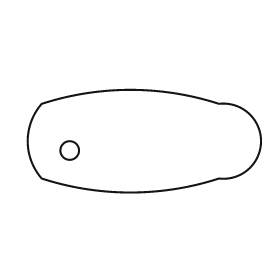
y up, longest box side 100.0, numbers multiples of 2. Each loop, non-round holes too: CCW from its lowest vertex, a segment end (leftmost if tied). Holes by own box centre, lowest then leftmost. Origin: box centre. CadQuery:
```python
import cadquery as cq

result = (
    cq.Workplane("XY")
    .moveTo(-44.0, -16.0)
    .threePointArc((-6.0, -22.0), (32.0, -16.0))
    .threePointArc((50.0, 0.0), (32.0, 16.0))
    .threePointArc((-6.0, 22.0), (-44.0, 16.0))
    .threePointArc((-50.0, 0.0), (-44.0, -16.0))
    .close()
    .moveTo(-32.0, -4.0)
    .circle(4.0)
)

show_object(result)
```